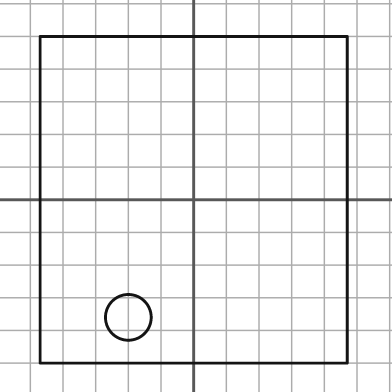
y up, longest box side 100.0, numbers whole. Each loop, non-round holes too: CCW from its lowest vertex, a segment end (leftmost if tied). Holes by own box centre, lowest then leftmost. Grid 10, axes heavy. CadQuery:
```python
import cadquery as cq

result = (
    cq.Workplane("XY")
    .moveTo(-47.0, -50.0)
    .lineTo(47.0, -50.0)
    .lineTo(47.0, 50.0)
    .lineTo(-47.0, 50.0)
    .close()
    .moveTo(-20.0, -36.0)
    .circle(7.0)
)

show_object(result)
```